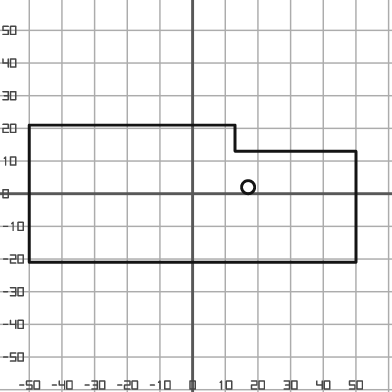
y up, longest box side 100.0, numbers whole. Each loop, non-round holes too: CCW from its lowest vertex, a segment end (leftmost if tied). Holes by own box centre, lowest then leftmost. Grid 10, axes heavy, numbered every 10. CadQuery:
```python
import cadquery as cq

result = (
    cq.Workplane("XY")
    .moveTo(-50.0, -21.0)
    .lineTo(50.0, -21.0)
    .lineTo(50.0, 13.0)
    .lineTo(13.0, 13.0)
    .lineTo(13.0, 21.0)
    .lineTo(-50.0, 21.0)
    .close()
    .moveTo(17.0, 2.0)
    .circle(2.0)
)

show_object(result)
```